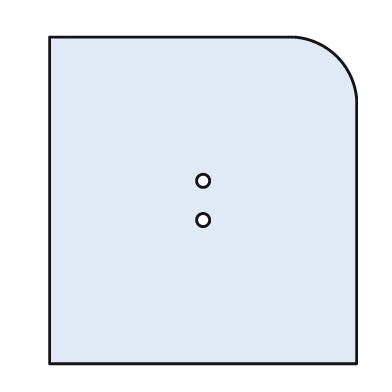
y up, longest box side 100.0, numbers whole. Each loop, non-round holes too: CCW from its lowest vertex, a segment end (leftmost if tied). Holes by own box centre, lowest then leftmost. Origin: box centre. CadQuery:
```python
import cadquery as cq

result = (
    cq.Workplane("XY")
    .moveTo(-47.0, -50.0)
    .lineTo(47.0, -50.0)
    .lineTo(47.0, 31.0)
    .threePointArc((41.0, 44.0), (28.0, 50.0))
    .lineTo(-47.0, 50.0)
    .close()
    .moveTo(0.0, -6.0)
    .circle(2.0)
    .moveTo(0.0, 6.0)
    .circle(2.0)
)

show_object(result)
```